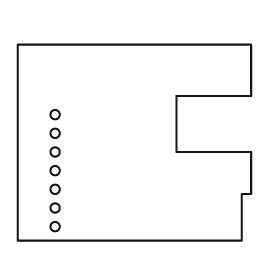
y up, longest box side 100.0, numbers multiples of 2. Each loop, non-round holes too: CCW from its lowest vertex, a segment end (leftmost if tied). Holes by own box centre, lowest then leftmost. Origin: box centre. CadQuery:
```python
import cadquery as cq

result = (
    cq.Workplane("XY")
    .moveTo(-50.0, -42.0)
    .lineTo(46.0, -42.0)
    .lineTo(46.0, -22.0)
    .lineTo(50.0, -22.0)
    .lineTo(50.0, -4.0)
    .lineTo(18.0, -4.0)
    .lineTo(18.0, 20.0)
    .lineTo(50.0, 20.0)
    .lineTo(50.0, 42.0)
    .lineTo(-50.0, 42.0)
    .close()
    .moveTo(-34.0, -36.0)
    .circle(2.0)
    .moveTo(-34.0, -28.0)
    .circle(2.0)
    .moveTo(-34.0, -20.0)
    .circle(2.0)
    .moveTo(-34.0, -12.0)
    .circle(2.0)
    .moveTo(-34.0, -4.0)
    .circle(2.0)
    .moveTo(-34.0, 4.0)
    .circle(2.0)
    .moveTo(-34.0, 12.0)
    .circle(2.0)
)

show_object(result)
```